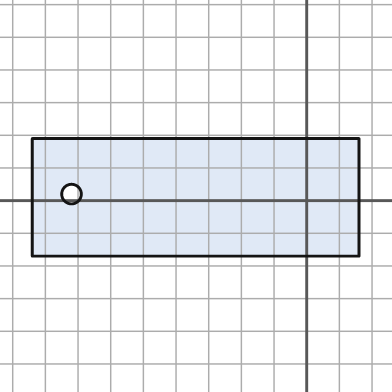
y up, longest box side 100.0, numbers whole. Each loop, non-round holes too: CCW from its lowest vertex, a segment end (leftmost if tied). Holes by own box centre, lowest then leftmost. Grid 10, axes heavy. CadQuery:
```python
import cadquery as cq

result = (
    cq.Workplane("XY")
    .moveTo(-84.0, -17.0)
    .lineTo(16.0, -17.0)
    .lineTo(16.0, 19.0)
    .lineTo(-84.0, 19.0)
    .close()
    .moveTo(-72.0, 2.0)
    .circle(3.0)
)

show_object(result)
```